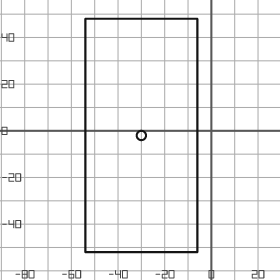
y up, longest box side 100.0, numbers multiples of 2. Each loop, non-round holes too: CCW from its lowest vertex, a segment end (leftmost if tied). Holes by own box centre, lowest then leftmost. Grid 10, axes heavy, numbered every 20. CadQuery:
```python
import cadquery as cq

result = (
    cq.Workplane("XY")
    .moveTo(-54.0, -52.0)
    .lineTo(-6.0, -52.0)
    .lineTo(-6.0, 48.0)
    .lineTo(-54.0, 48.0)
    .close()
    .moveTo(-30.0, -2.0)
    .circle(2.0)
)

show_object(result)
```